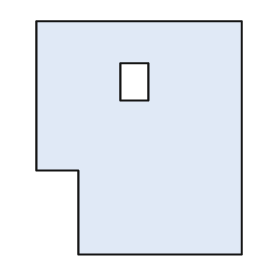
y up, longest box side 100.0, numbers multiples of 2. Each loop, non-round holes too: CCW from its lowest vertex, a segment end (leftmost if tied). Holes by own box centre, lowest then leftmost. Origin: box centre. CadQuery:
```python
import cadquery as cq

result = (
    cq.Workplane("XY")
    .moveTo(-26.0, -50.0)
    .lineTo(44.0, -50.0)
    .lineTo(44.0, 50.0)
    .lineTo(-44.0, 50.0)
    .lineTo(-44.0, -14.0)
    .lineTo(-26.0, -14.0)
    .close()
    .moveTo(-8.0, 16.0)
    .lineTo(4.0, 16.0)
    .lineTo(4.0, 32.0)
    .lineTo(-8.0, 32.0)
    .close()
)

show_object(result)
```